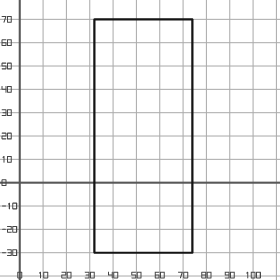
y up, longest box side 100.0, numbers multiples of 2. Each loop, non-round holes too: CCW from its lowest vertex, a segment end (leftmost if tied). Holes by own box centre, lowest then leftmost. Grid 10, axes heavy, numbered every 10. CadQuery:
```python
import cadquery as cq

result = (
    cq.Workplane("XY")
    .moveTo(32.0, -30.0)
    .lineTo(74.0, -30.0)
    .lineTo(74.0, 70.0)
    .lineTo(32.0, 70.0)
    .close()
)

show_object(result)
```